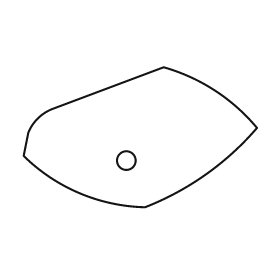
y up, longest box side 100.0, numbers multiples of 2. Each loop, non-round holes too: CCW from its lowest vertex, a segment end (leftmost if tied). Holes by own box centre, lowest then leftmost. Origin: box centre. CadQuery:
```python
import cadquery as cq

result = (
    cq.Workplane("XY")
    .moveTo(2.0, -30.0)
    .threePointArc((28.0, -16.0), (50.0, 4.0))
    .threePointArc((32.0, 20.0), (10.0, 30.0))
    .lineTo(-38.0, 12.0)
    .threePointArc((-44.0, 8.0), (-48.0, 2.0))
    .lineTo(-50.0, -8.0)
    .threePointArc((-26.0, -24.0), (2.0, -30.0))
    .close()
    .moveTo(-6.0, -10.0)
    .circle(4.0)
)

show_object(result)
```